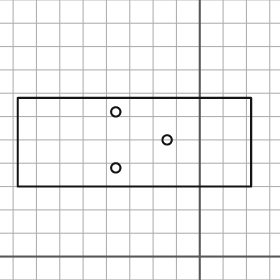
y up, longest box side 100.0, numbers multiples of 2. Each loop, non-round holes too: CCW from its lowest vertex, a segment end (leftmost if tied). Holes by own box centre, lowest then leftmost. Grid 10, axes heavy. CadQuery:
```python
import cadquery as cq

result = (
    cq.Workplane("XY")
    .moveTo(-78.0, 30.0)
    .lineTo(22.0, 30.0)
    .lineTo(22.0, 68.0)
    .lineTo(-78.0, 68.0)
    .close()
    .moveTo(-36.0, 38.0)
    .circle(2.0)
    .moveTo(-14.0, 50.0)
    .circle(2.0)
    .moveTo(-36.0, 62.0)
    .circle(2.0)
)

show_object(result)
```